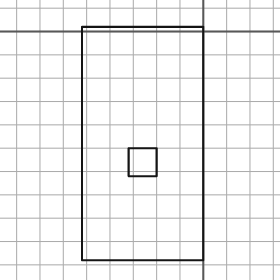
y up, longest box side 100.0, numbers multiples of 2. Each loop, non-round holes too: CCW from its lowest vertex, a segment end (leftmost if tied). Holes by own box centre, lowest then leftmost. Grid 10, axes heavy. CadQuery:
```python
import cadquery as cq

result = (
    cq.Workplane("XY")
    .moveTo(-52.0, -98.0)
    .lineTo(0.0, -98.0)
    .lineTo(0.0, 2.0)
    .lineTo(-52.0, 2.0)
    .close()
    .moveTo(-32.0, -62.0)
    .lineTo(-20.0, -62.0)
    .lineTo(-20.0, -50.0)
    .lineTo(-32.0, -50.0)
    .close()
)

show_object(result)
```